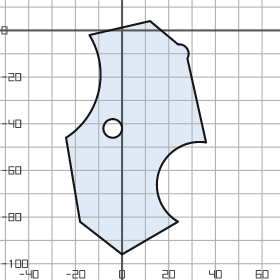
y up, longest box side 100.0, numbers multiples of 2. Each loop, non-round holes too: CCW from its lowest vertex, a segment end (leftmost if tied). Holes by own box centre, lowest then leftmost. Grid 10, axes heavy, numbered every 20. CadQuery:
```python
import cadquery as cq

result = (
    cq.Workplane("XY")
    .moveTo(0.0, -96.0)
    .lineTo(24.0, -82.0)
    .threePointArc((16.0, -60.0), (36.0, -48.0))
    .lineTo(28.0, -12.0)
    .threePointArc((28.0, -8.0), (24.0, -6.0))
    .lineTo(12.0, 4.0)
    .lineTo(-14.0, -2.0)
    .threePointArc((-10.0, -26.0), (-24.0, -46.0))
    .lineTo(-18.0, -82.0)
    .close()
    .moveTo(-4.0, -42.0)
    .circle(4.0)
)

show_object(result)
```